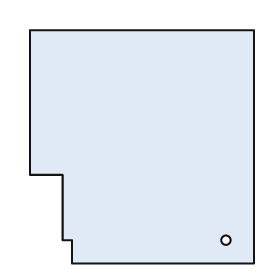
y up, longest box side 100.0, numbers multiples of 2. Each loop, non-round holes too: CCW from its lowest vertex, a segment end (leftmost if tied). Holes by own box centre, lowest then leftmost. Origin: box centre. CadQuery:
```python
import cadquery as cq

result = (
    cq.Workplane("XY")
    .moveTo(-30.0, -50.0)
    .lineTo(48.0, -50.0)
    .lineTo(48.0, 50.0)
    .lineTo(-48.0, 50.0)
    .lineTo(-48.0, -12.0)
    .lineTo(-34.0, -12.0)
    .lineTo(-34.0, -40.0)
    .lineTo(-30.0, -40.0)
    .close()
    .moveTo(36.0, -40.0)
    .circle(2.0)
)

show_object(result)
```